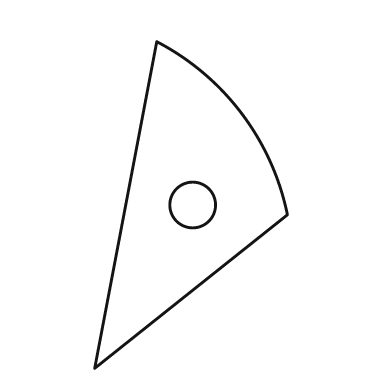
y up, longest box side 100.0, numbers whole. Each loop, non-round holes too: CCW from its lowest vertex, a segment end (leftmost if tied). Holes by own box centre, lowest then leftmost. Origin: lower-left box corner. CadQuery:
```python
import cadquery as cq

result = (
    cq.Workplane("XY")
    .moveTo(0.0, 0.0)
    .lineTo(59.0, 47.0)
    .threePointArc((45.0, 78.0), (19.0, 100.0))
    .close()
    .moveTo(30.0, 50.0)
    .circle(7.0)
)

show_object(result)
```